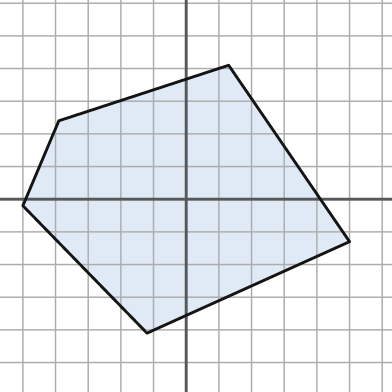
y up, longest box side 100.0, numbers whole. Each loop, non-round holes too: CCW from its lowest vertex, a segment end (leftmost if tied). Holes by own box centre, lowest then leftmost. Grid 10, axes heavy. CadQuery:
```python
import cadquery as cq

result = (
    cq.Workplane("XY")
    .moveTo(-12.0, -41.0)
    .lineTo(50.0, -13.0)
    .lineTo(13.0, 41.0)
    .lineTo(-39.0, 24.0)
    .lineTo(-50.0, -2.0)
    .close()
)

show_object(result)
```